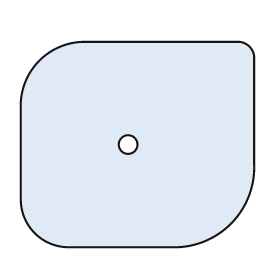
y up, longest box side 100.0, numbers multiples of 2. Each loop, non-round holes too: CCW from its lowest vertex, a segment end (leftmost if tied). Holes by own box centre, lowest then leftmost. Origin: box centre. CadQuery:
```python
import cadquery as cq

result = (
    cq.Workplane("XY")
    .moveTo(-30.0, -44.0)
    .lineTo(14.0, -44.0)
    .threePointArc((40.0, -34.0), (50.0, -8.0))
    .lineTo(50.0, 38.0)
    .threePointArc((48.0, 42.0), (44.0, 44.0))
    .lineTo(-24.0, 44.0)
    .threePointArc((-42.0, 36.0), (-50.0, 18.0))
    .lineTo(-50.0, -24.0)
    .threePointArc((-44.0, -38.0), (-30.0, -44.0))
    .close()
    .moveTo(-4.0, 0.0)
    .circle(4.0)
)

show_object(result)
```